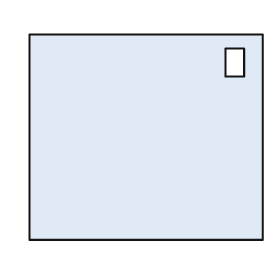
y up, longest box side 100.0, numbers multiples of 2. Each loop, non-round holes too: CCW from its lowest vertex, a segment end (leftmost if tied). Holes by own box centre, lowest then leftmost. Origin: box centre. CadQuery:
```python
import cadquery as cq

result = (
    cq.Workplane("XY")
    .moveTo(-50.0, -44.0)
    .lineTo(50.0, -44.0)
    .lineTo(50.0, 44.0)
    .lineTo(-50.0, 44.0)
    .close()
    .moveTo(34.0, 26.0)
    .lineTo(42.0, 26.0)
    .lineTo(42.0, 38.0)
    .lineTo(34.0, 38.0)
    .close()
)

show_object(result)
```